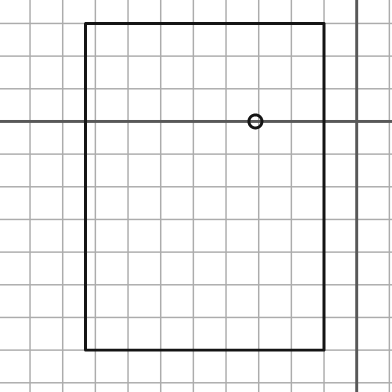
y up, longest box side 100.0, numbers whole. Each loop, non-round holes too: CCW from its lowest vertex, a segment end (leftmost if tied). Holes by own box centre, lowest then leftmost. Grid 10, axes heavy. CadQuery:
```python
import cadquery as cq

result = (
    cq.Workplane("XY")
    .moveTo(-83.0, -70.0)
    .lineTo(-10.0, -70.0)
    .lineTo(-10.0, 30.0)
    .lineTo(-83.0, 30.0)
    .close()
    .moveTo(-31.0, 0.0)
    .circle(2.0)
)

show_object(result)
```